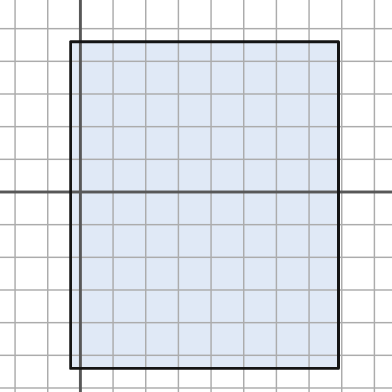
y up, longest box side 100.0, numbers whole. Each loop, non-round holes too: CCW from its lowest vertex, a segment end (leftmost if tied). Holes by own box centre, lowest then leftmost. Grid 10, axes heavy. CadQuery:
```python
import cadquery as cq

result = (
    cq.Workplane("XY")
    .moveTo(-3.0, -54.0)
    .lineTo(79.0, -54.0)
    .lineTo(79.0, 46.0)
    .lineTo(-3.0, 46.0)
    .close()
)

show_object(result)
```